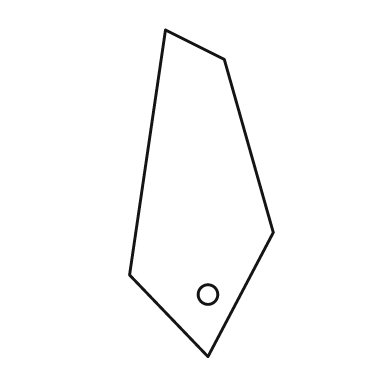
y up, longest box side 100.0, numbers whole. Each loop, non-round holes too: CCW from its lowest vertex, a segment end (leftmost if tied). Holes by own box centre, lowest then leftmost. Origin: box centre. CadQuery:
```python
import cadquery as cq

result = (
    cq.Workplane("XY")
    .moveTo(2.0, -50.0)
    .lineTo(22.0, -12.0)
    .lineTo(7.0, 41.0)
    .lineTo(-11.0, 50.0)
    .lineTo(-22.0, -25.0)
    .close()
    .moveTo(2.0, -31.0)
    .circle(3.0)
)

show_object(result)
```